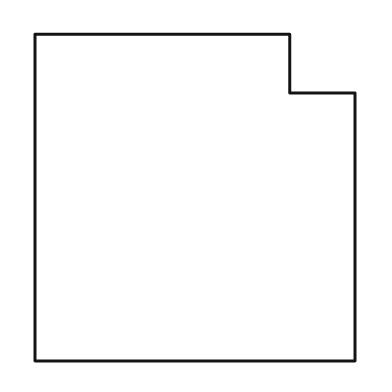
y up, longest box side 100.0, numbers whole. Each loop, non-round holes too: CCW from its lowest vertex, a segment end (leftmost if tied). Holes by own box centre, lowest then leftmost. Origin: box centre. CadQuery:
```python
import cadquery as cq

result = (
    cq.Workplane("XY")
    .moveTo(-49.0, -50.0)
    .lineTo(49.0, -50.0)
    .lineTo(49.0, 32.0)
    .lineTo(29.0, 32.0)
    .lineTo(29.0, 50.0)
    .lineTo(-49.0, 50.0)
    .close()
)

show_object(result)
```